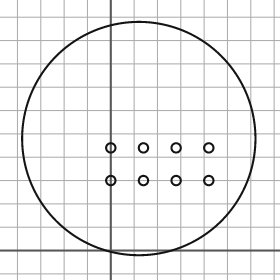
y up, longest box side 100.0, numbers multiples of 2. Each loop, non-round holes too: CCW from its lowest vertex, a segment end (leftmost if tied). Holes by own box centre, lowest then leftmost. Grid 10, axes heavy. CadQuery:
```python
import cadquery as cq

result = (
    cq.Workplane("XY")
    .moveTo(12.0, 48.0)
    .circle(50.0)
    .moveTo(0.0, 30.0)
    .circle(2.0)
    .moveTo(14.0, 30.0)
    .circle(2.0)
    .moveTo(28.0, 30.0)
    .circle(2.0)
    .moveTo(42.0, 30.0)
    .circle(2.0)
    .moveTo(0.0, 44.0)
    .circle(2.0)
    .moveTo(14.0, 44.0)
    .circle(2.0)
    .moveTo(28.0, 44.0)
    .circle(2.0)
    .moveTo(42.0, 44.0)
    .circle(2.0)
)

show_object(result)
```